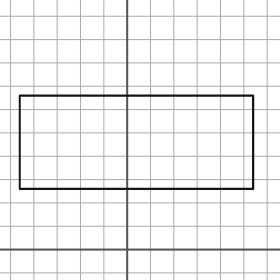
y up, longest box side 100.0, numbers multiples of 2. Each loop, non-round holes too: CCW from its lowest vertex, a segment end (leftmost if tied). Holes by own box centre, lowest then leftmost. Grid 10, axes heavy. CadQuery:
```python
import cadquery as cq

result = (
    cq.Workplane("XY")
    .moveTo(-46.0, 26.0)
    .lineTo(54.0, 26.0)
    .lineTo(54.0, 66.0)
    .lineTo(-46.0, 66.0)
    .close()
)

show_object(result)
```